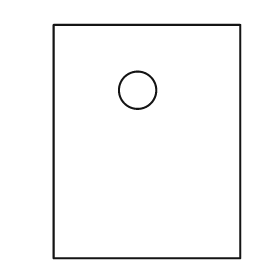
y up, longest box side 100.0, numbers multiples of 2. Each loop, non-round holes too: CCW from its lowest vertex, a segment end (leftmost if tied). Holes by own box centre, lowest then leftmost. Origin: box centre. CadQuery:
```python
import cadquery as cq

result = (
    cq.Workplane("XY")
    .moveTo(-40.0, -50.0)
    .lineTo(40.0, -50.0)
    .lineTo(40.0, 50.0)
    .lineTo(-40.0, 50.0)
    .close()
    .moveTo(-4.0, 22.0)
    .circle(8.0)
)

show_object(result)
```